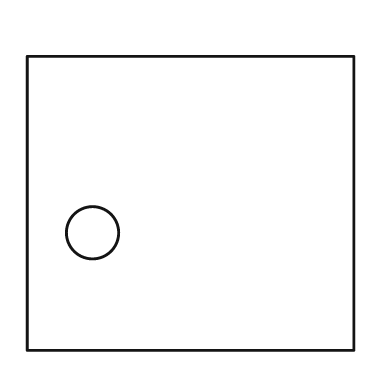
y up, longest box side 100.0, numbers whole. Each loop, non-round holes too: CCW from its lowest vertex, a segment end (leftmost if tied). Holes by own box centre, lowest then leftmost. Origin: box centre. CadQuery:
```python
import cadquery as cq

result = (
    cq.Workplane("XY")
    .moveTo(-50.0, -45.0)
    .lineTo(50.0, -45.0)
    .lineTo(50.0, 45.0)
    .lineTo(-50.0, 45.0)
    .close()
    .moveTo(-30.0, -9.0)
    .circle(8.0)
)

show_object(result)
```